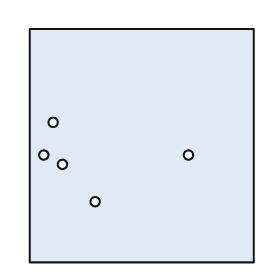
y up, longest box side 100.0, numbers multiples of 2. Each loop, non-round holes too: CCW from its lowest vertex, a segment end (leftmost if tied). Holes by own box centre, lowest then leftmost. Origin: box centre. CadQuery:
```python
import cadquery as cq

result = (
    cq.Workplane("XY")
    .moveTo(-48.0, -50.0)
    .lineTo(48.0, -50.0)
    .lineTo(48.0, 50.0)
    .lineTo(-48.0, 50.0)
    .close()
    .moveTo(-20.0, -24.0)
    .circle(2.0)
    .moveTo(-34.0, -8.0)
    .circle(2.0)
    .moveTo(-42.0, -4.0)
    .circle(2.0)
    .moveTo(20.0, -4.0)
    .circle(2.0)
    .moveTo(-38.0, 10.0)
    .circle(2.0)
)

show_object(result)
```